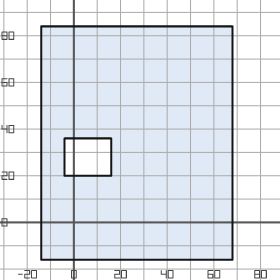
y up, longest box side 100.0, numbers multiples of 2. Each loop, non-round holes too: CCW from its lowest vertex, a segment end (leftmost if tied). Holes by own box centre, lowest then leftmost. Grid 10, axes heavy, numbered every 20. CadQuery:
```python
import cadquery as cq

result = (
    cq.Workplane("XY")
    .moveTo(-14.0, -16.0)
    .lineTo(68.0, -16.0)
    .lineTo(68.0, 84.0)
    .lineTo(-14.0, 84.0)
    .close()
    .moveTo(-4.0, 20.0)
    .lineTo(16.0, 20.0)
    .lineTo(16.0, 36.0)
    .lineTo(-4.0, 36.0)
    .close()
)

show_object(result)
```